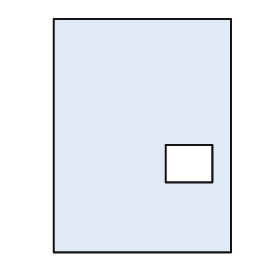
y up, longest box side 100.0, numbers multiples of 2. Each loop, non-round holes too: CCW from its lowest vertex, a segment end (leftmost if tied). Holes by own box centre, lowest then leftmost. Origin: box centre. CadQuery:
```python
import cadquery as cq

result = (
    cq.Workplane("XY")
    .moveTo(-38.0, -50.0)
    .lineTo(38.0, -50.0)
    .lineTo(38.0, 50.0)
    .lineTo(-38.0, 50.0)
    .close()
    .moveTo(10.0, -20.0)
    .lineTo(30.0, -20.0)
    .lineTo(30.0, -4.0)
    .lineTo(10.0, -4.0)
    .close()
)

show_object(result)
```